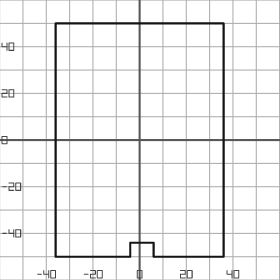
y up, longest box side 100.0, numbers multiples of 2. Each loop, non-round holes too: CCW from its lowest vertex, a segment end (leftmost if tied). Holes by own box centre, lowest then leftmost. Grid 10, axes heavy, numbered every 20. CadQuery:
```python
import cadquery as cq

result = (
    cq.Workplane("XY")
    .moveTo(-36.0, -50.0)
    .lineTo(-4.0, -50.0)
    .lineTo(-4.0, -44.0)
    .lineTo(6.0, -44.0)
    .lineTo(6.0, -50.0)
    .lineTo(36.0, -50.0)
    .lineTo(36.0, 50.0)
    .lineTo(-36.0, 50.0)
    .close()
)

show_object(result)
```